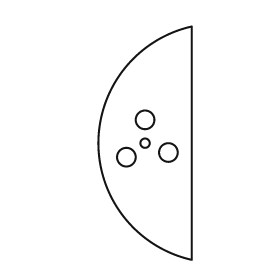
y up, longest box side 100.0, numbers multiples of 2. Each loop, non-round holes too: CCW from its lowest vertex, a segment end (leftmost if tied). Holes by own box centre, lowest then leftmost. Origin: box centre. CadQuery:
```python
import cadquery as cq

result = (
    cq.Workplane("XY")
    .moveTo(20.0, -50.0)
    .lineTo(20.0, 50.0)
    .threePointArc((-20.0, 0.0), (20.0, -50.0))
    .close()
    .moveTo(-8.0, -6.0)
    .circle(4.0)
    .moveTo(10.0, -4.0)
    .circle(4.0)
    .moveTo(0.0, 0.0)
    .circle(2.0)
    .moveTo(0.0, 10.0)
    .circle(4.0)
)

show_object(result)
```